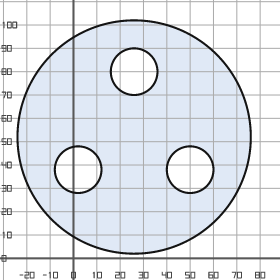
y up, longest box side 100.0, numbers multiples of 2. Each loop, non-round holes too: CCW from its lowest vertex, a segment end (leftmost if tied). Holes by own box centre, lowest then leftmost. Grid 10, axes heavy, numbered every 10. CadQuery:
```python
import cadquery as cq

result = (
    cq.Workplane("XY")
    .moveTo(26.0, 52.0)
    .circle(50.0)
    .moveTo(2.0, 38.0)
    .circle(10.0)
    .moveTo(50.0, 38.0)
    .circle(10.0)
    .moveTo(26.0, 80.0)
    .circle(10.0)
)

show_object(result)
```